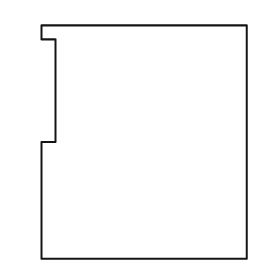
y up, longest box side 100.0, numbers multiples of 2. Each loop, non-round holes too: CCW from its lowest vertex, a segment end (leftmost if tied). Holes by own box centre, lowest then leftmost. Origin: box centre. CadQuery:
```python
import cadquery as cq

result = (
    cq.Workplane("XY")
    .moveTo(-44.0, -50.0)
    .lineTo(44.0, -50.0)
    .lineTo(44.0, 50.0)
    .lineTo(-44.0, 50.0)
    .lineTo(-44.0, 44.0)
    .lineTo(-38.0, 44.0)
    .lineTo(-38.0, 0.0)
    .lineTo(-44.0, 0.0)
    .close()
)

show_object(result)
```